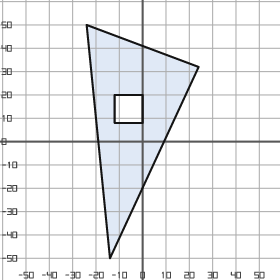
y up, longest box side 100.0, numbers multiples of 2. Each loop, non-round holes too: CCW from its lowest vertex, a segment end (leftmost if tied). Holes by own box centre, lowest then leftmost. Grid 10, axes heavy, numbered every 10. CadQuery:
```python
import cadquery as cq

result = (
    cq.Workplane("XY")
    .moveTo(-14.0, -50.0)
    .lineTo(24.0, 32.0)
    .lineTo(-24.0, 50.0)
    .close()
    .moveTo(-12.0, 8.0)
    .lineTo(0.0, 8.0)
    .lineTo(0.0, 20.0)
    .lineTo(-12.0, 20.0)
    .close()
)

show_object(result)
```